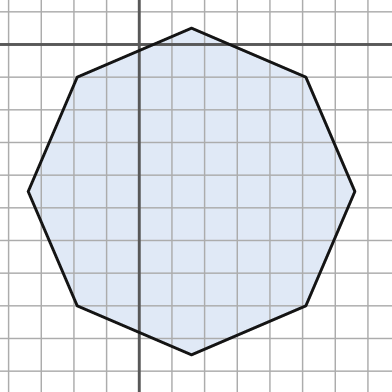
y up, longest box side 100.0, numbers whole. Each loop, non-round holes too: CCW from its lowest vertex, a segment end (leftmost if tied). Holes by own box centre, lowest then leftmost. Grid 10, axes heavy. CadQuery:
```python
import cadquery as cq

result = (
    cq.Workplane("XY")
    .moveTo(16.0, -95.0)
    .lineTo(51.0, -80.0)
    .lineTo(66.0, -45.0)
    .lineTo(51.0, -10.0)
    .lineTo(16.0, 5.0)
    .lineTo(-19.0, -10.0)
    .lineTo(-34.0, -45.0)
    .lineTo(-19.0, -80.0)
    .close()
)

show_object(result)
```